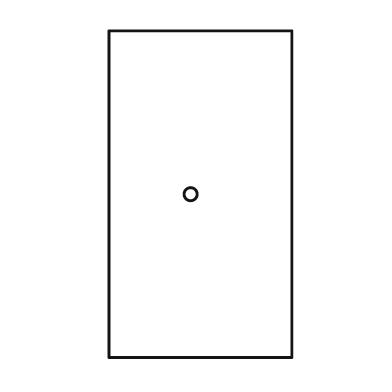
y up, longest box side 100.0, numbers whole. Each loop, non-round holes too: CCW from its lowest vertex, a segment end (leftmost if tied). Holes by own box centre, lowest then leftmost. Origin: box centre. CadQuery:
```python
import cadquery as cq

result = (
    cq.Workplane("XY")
    .moveTo(-28.0, -50.0)
    .lineTo(28.0, -50.0)
    .lineTo(28.0, 50.0)
    .lineTo(-28.0, 50.0)
    .close()
    .moveTo(-3.0, 0.0)
    .circle(2.0)
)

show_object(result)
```